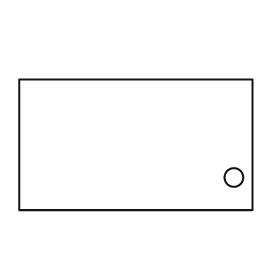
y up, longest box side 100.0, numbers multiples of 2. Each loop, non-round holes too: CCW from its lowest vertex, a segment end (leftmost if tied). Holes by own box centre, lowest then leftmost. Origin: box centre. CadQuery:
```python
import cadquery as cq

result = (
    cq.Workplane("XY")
    .moveTo(-50.0, -28.0)
    .lineTo(50.0, -28.0)
    .lineTo(50.0, 28.0)
    .lineTo(-50.0, 28.0)
    .close()
    .moveTo(42.0, -14.0)
    .circle(4.0)
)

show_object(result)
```